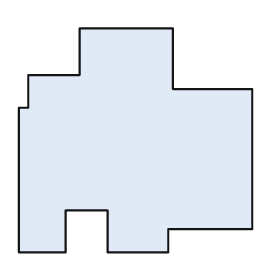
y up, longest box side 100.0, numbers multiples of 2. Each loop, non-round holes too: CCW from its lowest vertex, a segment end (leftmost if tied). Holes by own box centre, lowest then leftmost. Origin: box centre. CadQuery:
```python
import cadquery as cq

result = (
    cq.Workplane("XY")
    .moveTo(-50.0, -48.0)
    .lineTo(-30.0, -48.0)
    .lineTo(-30.0, -30.0)
    .lineTo(-12.0, -30.0)
    .lineTo(-12.0, -48.0)
    .lineTo(14.0, -48.0)
    .lineTo(14.0, -38.0)
    .lineTo(50.0, -38.0)
    .lineTo(50.0, 22.0)
    .lineTo(16.0, 22.0)
    .lineTo(16.0, 48.0)
    .lineTo(-24.0, 48.0)
    .lineTo(-24.0, 28.0)
    .lineTo(-46.0, 28.0)
    .lineTo(-46.0, 14.0)
    .lineTo(-50.0, 14.0)
    .close()
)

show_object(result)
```